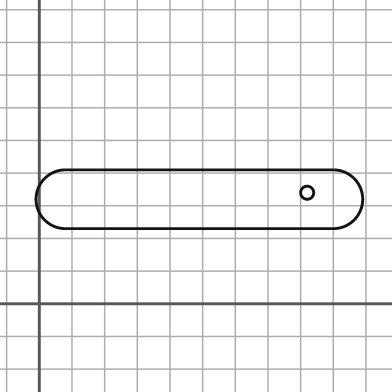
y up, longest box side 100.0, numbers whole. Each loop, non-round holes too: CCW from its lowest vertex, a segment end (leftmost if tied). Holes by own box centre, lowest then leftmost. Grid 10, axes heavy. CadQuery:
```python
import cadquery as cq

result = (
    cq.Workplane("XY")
    .moveTo(8.0, 23.0)
    .lineTo(90.0, 23.0)
    .threePointArc((99.0, 32.0), (90.0, 41.0))
    .lineTo(8.0, 41.0)
    .threePointArc((-1.0, 32.0), (8.0, 23.0))
    .close()
    .moveTo(82.0, 34.0)
    .circle(2.0)
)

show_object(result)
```